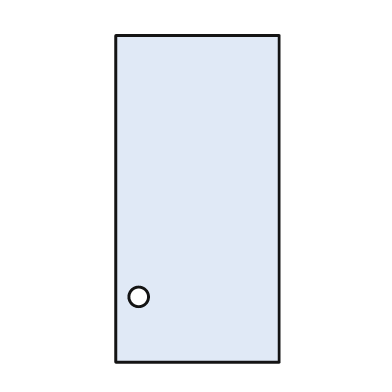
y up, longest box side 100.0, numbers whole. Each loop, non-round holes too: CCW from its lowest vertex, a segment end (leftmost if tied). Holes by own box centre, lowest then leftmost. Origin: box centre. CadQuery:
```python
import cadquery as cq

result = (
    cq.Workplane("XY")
    .moveTo(-25.0, -50.0)
    .lineTo(25.0, -50.0)
    .lineTo(25.0, 50.0)
    .lineTo(-25.0, 50.0)
    .close()
    .moveTo(-18.0, -30.0)
    .circle(3.0)
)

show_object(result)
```